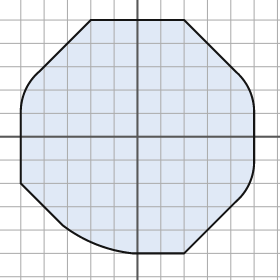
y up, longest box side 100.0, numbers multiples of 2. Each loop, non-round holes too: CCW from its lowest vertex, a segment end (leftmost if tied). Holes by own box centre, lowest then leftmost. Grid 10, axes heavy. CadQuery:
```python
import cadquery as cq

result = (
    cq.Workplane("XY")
    .moveTo(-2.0, -50.0)
    .lineTo(20.0, -50.0)
    .lineTo(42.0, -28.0)
    .threePointArc((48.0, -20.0), (50.0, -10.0))
    .lineTo(50.0, 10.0)
    .threePointArc((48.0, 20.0), (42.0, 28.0))
    .lineTo(20.0, 50.0)
    .lineTo(-20.0, 50.0)
    .lineTo(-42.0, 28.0)
    .threePointArc((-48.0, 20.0), (-50.0, 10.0))
    .lineTo(-50.0, -20.0)
    .lineTo(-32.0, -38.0)
    .threePointArc((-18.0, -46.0), (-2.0, -50.0))
    .close()
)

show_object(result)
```